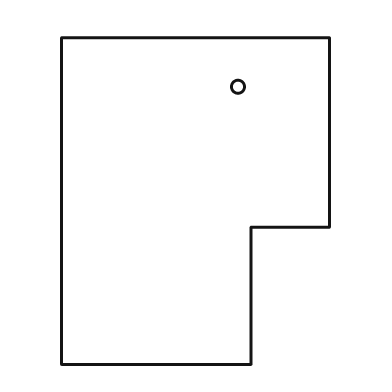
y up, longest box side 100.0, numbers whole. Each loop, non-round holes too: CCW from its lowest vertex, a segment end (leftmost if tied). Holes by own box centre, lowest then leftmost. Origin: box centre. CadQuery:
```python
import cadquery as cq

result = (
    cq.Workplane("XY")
    .moveTo(-41.0, -50.0)
    .lineTo(17.0, -50.0)
    .lineTo(17.0, -8.0)
    .lineTo(41.0, -8.0)
    .lineTo(41.0, 50.0)
    .lineTo(-41.0, 50.0)
    .close()
    .moveTo(13.0, 35.0)
    .circle(2.0)
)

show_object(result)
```